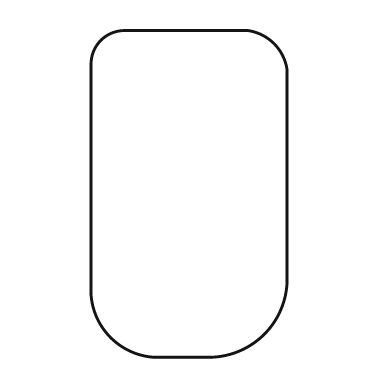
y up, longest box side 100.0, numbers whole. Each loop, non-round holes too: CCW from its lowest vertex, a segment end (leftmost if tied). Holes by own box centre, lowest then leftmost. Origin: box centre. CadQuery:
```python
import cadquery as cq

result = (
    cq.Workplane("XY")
    .moveTo(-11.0, -50.0)
    .lineTo(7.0, -50.0)
    .threePointArc((23.0, -43.0), (30.0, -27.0))
    .lineTo(30.0, 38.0)
    .threePointArc((26.0, 46.0), (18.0, 50.0))
    .lineTo(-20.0, 50.0)
    .threePointArc((-27.0, 47.0), (-30.0, 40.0))
    .lineTo(-30.0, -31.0)
    .threePointArc((-24.0, -44.0), (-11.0, -50.0))
    .close()
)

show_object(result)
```